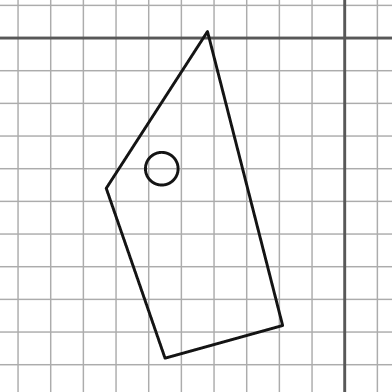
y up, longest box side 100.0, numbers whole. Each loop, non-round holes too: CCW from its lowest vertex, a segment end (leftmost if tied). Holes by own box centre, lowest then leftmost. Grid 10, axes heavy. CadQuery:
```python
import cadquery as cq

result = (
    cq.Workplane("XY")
    .moveTo(-55.0, -98.0)
    .lineTo(-19.0, -88.0)
    .lineTo(-42.0, 2.0)
    .lineTo(-73.0, -46.0)
    .close()
    .moveTo(-56.0, -40.0)
    .circle(5.0)
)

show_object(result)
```